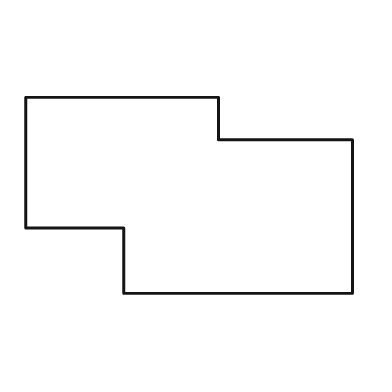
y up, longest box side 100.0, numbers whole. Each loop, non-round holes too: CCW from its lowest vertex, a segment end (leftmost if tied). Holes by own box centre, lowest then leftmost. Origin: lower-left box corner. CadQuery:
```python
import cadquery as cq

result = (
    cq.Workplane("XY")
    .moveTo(30.0, 0.0)
    .lineTo(100.0, 0.0)
    .lineTo(100.0, 47.0)
    .lineTo(59.0, 47.0)
    .lineTo(59.0, 60.0)
    .lineTo(0.0, 60.0)
    .lineTo(0.0, 20.0)
    .lineTo(30.0, 20.0)
    .close()
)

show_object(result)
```